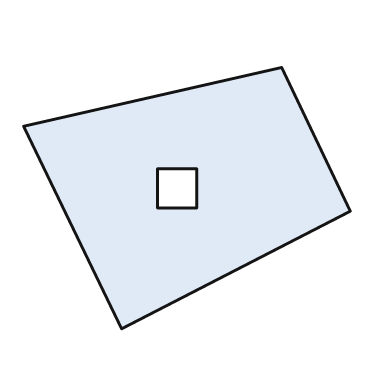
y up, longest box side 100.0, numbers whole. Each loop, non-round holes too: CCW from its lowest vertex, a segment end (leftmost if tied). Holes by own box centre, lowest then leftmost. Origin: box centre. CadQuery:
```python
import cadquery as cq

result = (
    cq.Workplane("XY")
    .moveTo(-20.0, -40.0)
    .lineTo(50.0, -4.0)
    .lineTo(29.0, 40.0)
    .lineTo(-50.0, 22.0)
    .close()
    .moveTo(-9.0, -3.0)
    .lineTo(3.0, -3.0)
    .lineTo(3.0, 9.0)
    .lineTo(-9.0, 9.0)
    .close()
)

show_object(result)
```